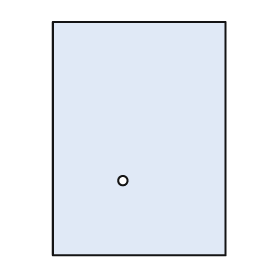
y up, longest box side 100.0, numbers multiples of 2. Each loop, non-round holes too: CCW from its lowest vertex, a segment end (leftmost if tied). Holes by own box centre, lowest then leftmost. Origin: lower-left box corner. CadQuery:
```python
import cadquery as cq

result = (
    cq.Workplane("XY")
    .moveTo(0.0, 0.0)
    .lineTo(74.0, 0.0)
    .lineTo(74.0, 100.0)
    .lineTo(0.0, 100.0)
    .close()
    .moveTo(30.0, 32.0)
    .circle(2.0)
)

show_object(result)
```